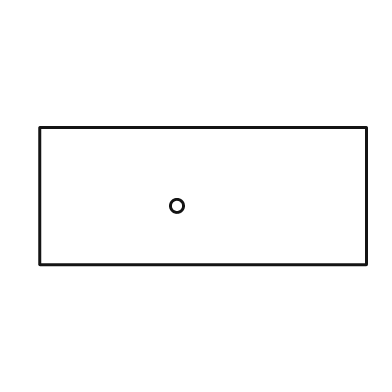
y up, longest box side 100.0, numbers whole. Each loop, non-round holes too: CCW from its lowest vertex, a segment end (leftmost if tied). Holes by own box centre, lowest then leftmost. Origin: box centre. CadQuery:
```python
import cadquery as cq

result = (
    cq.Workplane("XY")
    .moveTo(-50.0, -21.0)
    .lineTo(50.0, -21.0)
    .lineTo(50.0, 21.0)
    .lineTo(-50.0, 21.0)
    .close()
    .moveTo(-8.0, -3.0)
    .circle(2.0)
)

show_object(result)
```